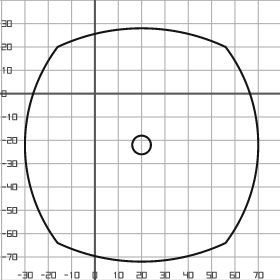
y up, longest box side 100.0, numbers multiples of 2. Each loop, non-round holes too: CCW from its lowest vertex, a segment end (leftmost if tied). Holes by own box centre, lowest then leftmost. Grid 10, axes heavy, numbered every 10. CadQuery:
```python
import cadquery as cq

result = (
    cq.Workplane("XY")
    .moveTo(-16.0, -64.0)
    .threePointArc((20.0, -72.0), (56.0, -64.0))
    .threePointArc((70.0, -22.0), (56.0, 20.0))
    .threePointArc((20.0, 28.0), (-16.0, 20.0))
    .threePointArc((-30.0, -22.0), (-16.0, -64.0))
    .close()
    .moveTo(20.0, -22.0)
    .circle(4.0)
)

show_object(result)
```